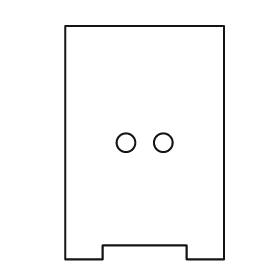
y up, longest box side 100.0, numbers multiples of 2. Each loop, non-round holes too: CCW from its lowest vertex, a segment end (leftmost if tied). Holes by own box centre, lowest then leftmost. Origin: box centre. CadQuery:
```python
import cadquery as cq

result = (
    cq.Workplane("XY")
    .moveTo(-34.0, -50.0)
    .lineTo(-18.0, -50.0)
    .lineTo(-18.0, -44.0)
    .lineTo(18.0, -44.0)
    .lineTo(18.0, -50.0)
    .lineTo(34.0, -50.0)
    .lineTo(34.0, 50.0)
    .lineTo(-34.0, 50.0)
    .close()
    .moveTo(-8.0, 0.0)
    .circle(4.0)
    .moveTo(8.0, 0.0)
    .circle(4.0)
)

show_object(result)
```